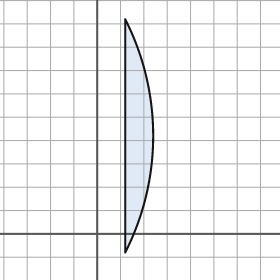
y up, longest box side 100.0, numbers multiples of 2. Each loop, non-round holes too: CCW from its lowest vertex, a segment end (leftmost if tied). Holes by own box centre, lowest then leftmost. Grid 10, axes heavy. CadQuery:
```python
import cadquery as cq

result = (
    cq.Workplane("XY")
    .moveTo(12.0, -8.0)
    .threePointArc((24.0, 42.0), (12.0, 92.0))
    .close()
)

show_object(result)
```